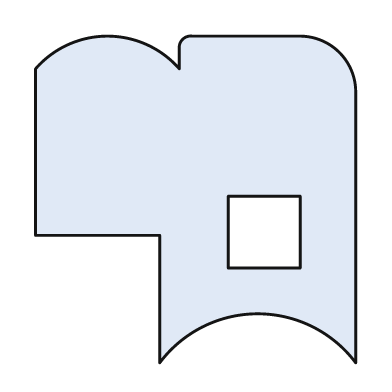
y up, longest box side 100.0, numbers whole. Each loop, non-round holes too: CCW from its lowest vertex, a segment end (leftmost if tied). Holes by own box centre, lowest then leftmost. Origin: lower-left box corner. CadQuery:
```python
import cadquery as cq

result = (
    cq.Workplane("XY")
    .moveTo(38.0, 0.0)
    .threePointArc((68.0, 15.0), (98.0, 0.0))
    .lineTo(98.0, 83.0)
    .threePointArc((93.0, 95.0), (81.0, 100.0))
    .lineTo(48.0, 100.0)
    .threePointArc((45.0, 99.0), (44.0, 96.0))
    .lineTo(44.0, 90.0)
    .threePointArc((22.0, 100.0), (0.0, 90.0))
    .lineTo(0.0, 39.0)
    .lineTo(38.0, 39.0)
    .close()
    .moveTo(59.0, 29.0)
    .lineTo(81.0, 29.0)
    .lineTo(81.0, 51.0)
    .lineTo(59.0, 51.0)
    .close()
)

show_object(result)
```